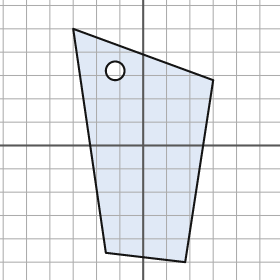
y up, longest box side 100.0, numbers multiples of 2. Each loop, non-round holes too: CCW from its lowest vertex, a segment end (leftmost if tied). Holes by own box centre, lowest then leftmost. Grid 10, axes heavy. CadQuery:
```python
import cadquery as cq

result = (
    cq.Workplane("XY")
    .moveTo(18.0, -50.0)
    .lineTo(30.0, 28.0)
    .lineTo(-30.0, 50.0)
    .lineTo(-16.0, -46.0)
    .close()
    .moveTo(-12.0, 32.0)
    .circle(4.0)
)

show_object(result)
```